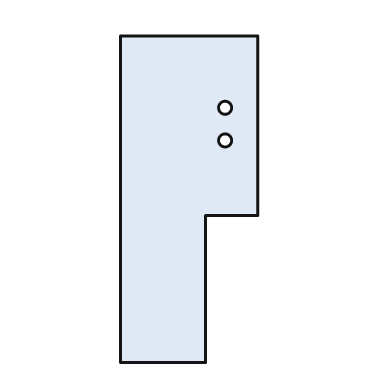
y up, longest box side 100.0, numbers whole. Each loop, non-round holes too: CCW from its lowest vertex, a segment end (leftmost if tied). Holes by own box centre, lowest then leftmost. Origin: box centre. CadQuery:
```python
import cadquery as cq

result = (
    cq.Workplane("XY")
    .moveTo(-21.0, -50.0)
    .lineTo(5.0, -50.0)
    .lineTo(5.0, -5.0)
    .lineTo(21.0, -5.0)
    .lineTo(21.0, 50.0)
    .lineTo(-21.0, 50.0)
    .close()
    .moveTo(11.0, 18.0)
    .circle(2.0)
    .moveTo(11.0, 28.0)
    .circle(2.0)
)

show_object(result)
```